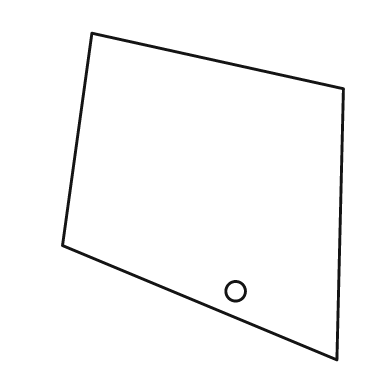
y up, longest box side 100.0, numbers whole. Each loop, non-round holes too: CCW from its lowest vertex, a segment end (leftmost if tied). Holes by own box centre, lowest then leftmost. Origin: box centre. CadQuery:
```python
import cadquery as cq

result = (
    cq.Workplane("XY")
    .moveTo(41.0, -50.0)
    .lineTo(43.0, 33.0)
    .lineTo(-34.0, 50.0)
    .lineTo(-43.0, -15.0)
    .close()
    .moveTo(10.0, -29.0)
    .circle(3.0)
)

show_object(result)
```